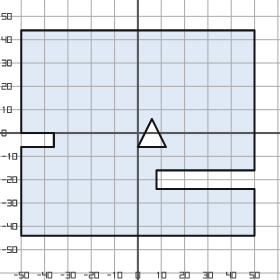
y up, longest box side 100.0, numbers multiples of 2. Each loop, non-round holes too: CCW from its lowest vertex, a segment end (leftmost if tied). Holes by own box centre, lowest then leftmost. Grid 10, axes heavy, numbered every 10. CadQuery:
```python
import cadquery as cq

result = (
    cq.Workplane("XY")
    .moveTo(-50.0, -44.0)
    .lineTo(50.0, -44.0)
    .lineTo(50.0, -24.0)
    .lineTo(8.0, -24.0)
    .lineTo(8.0, -16.0)
    .lineTo(50.0, -16.0)
    .lineTo(50.0, 44.0)
    .lineTo(-50.0, 44.0)
    .lineTo(-50.0, 0.0)
    .lineTo(-36.0, 0.0)
    .lineTo(-36.0, -6.0)
    .lineTo(-50.0, -6.0)
    .close()
    .moveTo(0.0, -6.0)
    .lineTo(12.0, -6.0)
    .lineTo(6.0, 6.0)
    .close()
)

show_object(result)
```